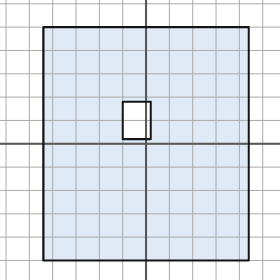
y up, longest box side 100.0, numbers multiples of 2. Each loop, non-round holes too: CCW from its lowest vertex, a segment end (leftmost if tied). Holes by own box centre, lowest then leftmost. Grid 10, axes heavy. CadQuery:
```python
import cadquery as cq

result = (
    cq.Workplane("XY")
    .moveTo(-44.0, -50.0)
    .lineTo(44.0, -50.0)
    .lineTo(44.0, 50.0)
    .lineTo(-44.0, 50.0)
    .close()
    .moveTo(-10.0, 2.0)
    .lineTo(2.0, 2.0)
    .lineTo(2.0, 18.0)
    .lineTo(-10.0, 18.0)
    .close()
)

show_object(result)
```